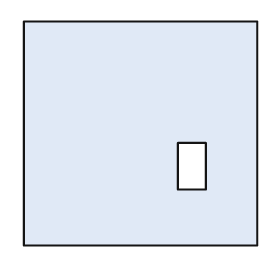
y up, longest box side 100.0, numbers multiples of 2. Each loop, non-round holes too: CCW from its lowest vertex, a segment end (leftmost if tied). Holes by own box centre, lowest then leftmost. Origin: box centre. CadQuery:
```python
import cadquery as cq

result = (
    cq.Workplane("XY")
    .moveTo(-50.0, -48.0)
    .lineTo(50.0, -48.0)
    .lineTo(50.0, 48.0)
    .lineTo(-50.0, 48.0)
    .close()
    .moveTo(16.0, -24.0)
    .lineTo(28.0, -24.0)
    .lineTo(28.0, -4.0)
    .lineTo(16.0, -4.0)
    .close()
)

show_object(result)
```